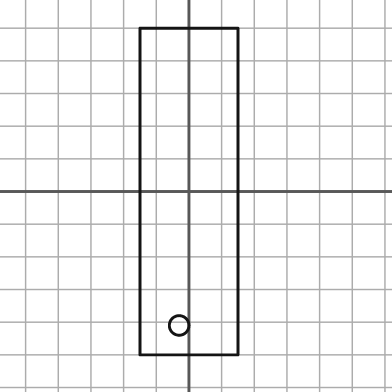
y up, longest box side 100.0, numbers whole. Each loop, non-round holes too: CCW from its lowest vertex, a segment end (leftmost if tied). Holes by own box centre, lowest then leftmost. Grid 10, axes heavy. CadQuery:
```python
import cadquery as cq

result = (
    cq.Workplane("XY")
    .moveTo(-15.0, -50.0)
    .lineTo(15.0, -50.0)
    .lineTo(15.0, 50.0)
    .lineTo(-15.0, 50.0)
    .close()
    .moveTo(-3.0, -41.0)
    .circle(3.0)
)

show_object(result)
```